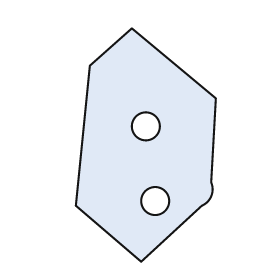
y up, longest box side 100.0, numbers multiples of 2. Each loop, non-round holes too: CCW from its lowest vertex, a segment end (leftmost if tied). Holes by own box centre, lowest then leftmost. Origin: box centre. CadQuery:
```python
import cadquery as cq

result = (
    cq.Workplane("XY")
    .moveTo(-2.0, -50.0)
    .lineTo(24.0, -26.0)
    .threePointArc((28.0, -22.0), (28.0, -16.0))
    .lineTo(30.0, 20.0)
    .lineTo(-6.0, 50.0)
    .lineTo(-24.0, 34.0)
    .lineTo(-30.0, -26.0)
    .close()
    .moveTo(4.0, -24.0)
    .circle(6.0)
    .moveTo(0.0, 8.0)
    .circle(6.0)
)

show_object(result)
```